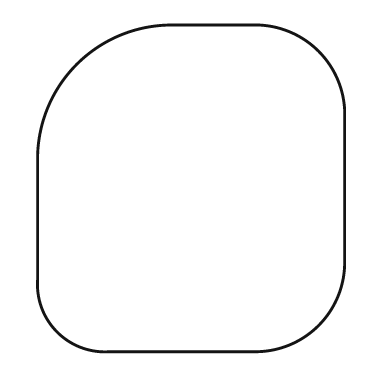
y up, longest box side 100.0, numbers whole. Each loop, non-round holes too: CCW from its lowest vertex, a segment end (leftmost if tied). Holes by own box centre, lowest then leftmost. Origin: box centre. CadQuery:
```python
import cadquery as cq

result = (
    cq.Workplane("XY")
    .moveTo(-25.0, -50.0)
    .lineTo(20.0, -50.0)
    .threePointArc((39.0, -42.0), (47.0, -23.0))
    .lineTo(47.0, 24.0)
    .threePointArc((39.0, 42.0), (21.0, 50.0))
    .lineTo(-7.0, 50.0)
    .threePointArc((-35.0, 38.0), (-47.0, 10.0))
    .lineTo(-47.0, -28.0)
    .threePointArc((-41.0, -44.0), (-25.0, -50.0))
    .close()
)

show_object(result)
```